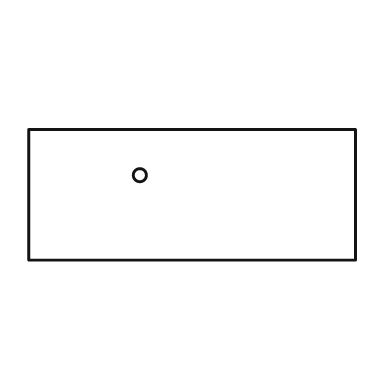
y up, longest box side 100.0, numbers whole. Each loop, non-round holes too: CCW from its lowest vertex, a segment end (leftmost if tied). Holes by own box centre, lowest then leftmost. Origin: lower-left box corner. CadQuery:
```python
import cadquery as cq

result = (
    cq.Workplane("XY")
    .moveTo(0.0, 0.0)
    .lineTo(100.0, 0.0)
    .lineTo(100.0, 40.0)
    .lineTo(0.0, 40.0)
    .close()
    .moveTo(34.0, 26.0)
    .circle(2.0)
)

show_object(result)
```